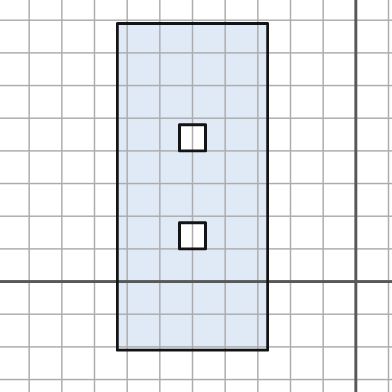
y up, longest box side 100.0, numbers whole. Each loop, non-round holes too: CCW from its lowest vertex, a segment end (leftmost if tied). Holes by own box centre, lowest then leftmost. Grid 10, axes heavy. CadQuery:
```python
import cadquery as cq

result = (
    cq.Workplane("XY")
    .moveTo(-73.0, -21.0)
    .lineTo(-27.0, -21.0)
    .lineTo(-27.0, 79.0)
    .lineTo(-73.0, 79.0)
    .close()
    .moveTo(-54.0, 10.0)
    .lineTo(-46.0, 10.0)
    .lineTo(-46.0, 18.0)
    .lineTo(-54.0, 18.0)
    .close()
    .moveTo(-54.0, 40.0)
    .lineTo(-46.0, 40.0)
    .lineTo(-46.0, 48.0)
    .lineTo(-54.0, 48.0)
    .close()
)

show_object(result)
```